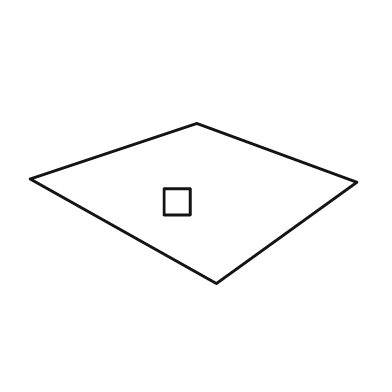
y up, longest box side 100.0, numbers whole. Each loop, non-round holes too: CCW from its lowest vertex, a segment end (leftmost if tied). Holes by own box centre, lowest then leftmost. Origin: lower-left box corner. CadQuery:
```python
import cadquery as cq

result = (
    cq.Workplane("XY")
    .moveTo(57.0, 0.0)
    .lineTo(100.0, 31.0)
    .lineTo(51.0, 49.0)
    .lineTo(0.0, 32.0)
    .close()
    .moveTo(41.0, 21.0)
    .lineTo(49.0, 21.0)
    .lineTo(49.0, 29.0)
    .lineTo(41.0, 29.0)
    .close()
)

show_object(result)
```